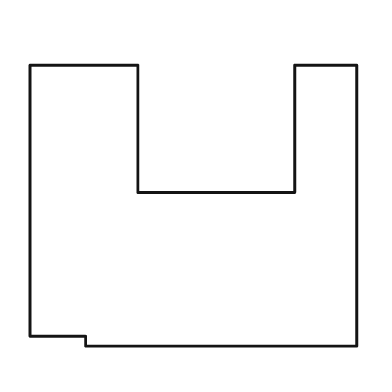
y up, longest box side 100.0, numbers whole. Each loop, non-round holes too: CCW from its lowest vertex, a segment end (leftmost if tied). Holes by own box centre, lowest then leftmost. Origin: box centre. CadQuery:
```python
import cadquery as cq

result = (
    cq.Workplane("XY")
    .moveTo(-33.0, -43.0)
    .lineTo(50.0, -43.0)
    .lineTo(50.0, 43.0)
    .lineTo(31.0, 43.0)
    .lineTo(31.0, 4.0)
    .lineTo(-17.0, 4.0)
    .lineTo(-17.0, 43.0)
    .lineTo(-50.0, 43.0)
    .lineTo(-50.0, -40.0)
    .lineTo(-33.0, -40.0)
    .close()
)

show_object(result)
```